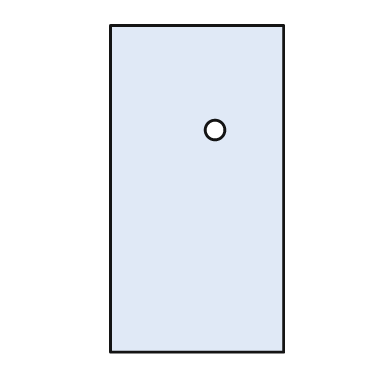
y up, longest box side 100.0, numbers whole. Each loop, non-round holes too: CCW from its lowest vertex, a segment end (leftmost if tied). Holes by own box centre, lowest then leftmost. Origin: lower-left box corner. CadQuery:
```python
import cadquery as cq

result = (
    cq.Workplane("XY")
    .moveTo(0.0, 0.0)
    .lineTo(53.0, 0.0)
    .lineTo(53.0, 100.0)
    .lineTo(0.0, 100.0)
    .close()
    .moveTo(32.0, 68.0)
    .circle(3.0)
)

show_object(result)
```